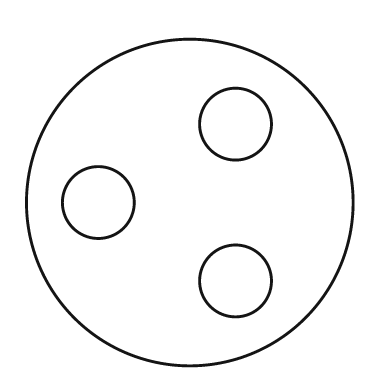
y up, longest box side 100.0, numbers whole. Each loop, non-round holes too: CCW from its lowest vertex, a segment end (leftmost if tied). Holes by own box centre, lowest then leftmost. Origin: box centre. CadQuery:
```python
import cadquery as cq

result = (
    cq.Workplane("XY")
    .moveTo(0.0, 0.0)
    .circle(50.0)
    .moveTo(14.0, -24.0)
    .circle(11.0)
    .moveTo(-28.0, 0.0)
    .circle(11.0)
    .moveTo(14.0, 24.0)
    .circle(11.0)
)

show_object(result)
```